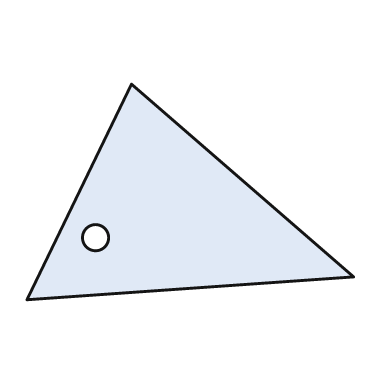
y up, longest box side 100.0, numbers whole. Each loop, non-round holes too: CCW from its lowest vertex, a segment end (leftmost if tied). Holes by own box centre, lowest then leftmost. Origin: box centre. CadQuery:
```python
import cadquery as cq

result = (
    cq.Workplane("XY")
    .moveTo(-50.0, -33.0)
    .lineTo(50.0, -26.0)
    .lineTo(-18.0, 33.0)
    .close()
    .moveTo(-29.0, -14.0)
    .circle(4.0)
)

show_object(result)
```